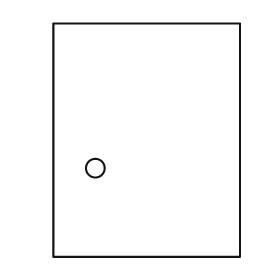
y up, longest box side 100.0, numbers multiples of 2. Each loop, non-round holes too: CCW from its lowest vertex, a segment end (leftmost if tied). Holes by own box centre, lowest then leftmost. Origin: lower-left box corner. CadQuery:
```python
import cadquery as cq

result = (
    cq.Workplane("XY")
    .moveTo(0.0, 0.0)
    .lineTo(80.0, 0.0)
    .lineTo(80.0, 100.0)
    .lineTo(0.0, 100.0)
    .close()
    .moveTo(18.0, 38.0)
    .circle(4.0)
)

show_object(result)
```